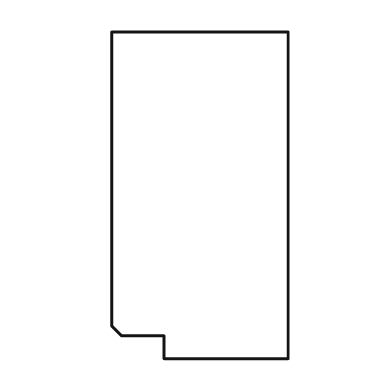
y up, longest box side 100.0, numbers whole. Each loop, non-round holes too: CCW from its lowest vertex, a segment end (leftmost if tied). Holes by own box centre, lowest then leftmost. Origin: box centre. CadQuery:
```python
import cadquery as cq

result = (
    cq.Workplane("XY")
    .moveTo(-11.0, -50.0)
    .lineTo(27.0, -50.0)
    .lineTo(27.0, 50.0)
    .lineTo(-27.0, 50.0)
    .lineTo(-27.0, -40.0)
    .lineTo(-24.0, -43.0)
    .lineTo(-11.0, -43.0)
    .close()
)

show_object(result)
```